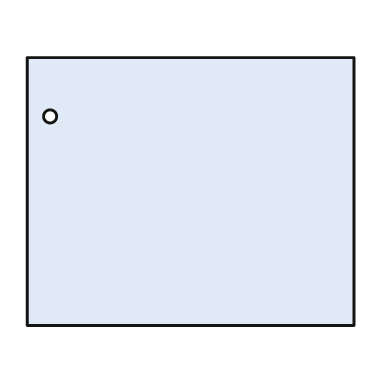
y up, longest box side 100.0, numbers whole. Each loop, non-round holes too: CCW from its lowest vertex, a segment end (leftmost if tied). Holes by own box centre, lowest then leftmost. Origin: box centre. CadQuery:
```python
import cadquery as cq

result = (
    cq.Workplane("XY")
    .moveTo(-50.0, -41.0)
    .lineTo(50.0, -41.0)
    .lineTo(50.0, 41.0)
    .lineTo(-50.0, 41.0)
    .close()
    .moveTo(-43.0, 23.0)
    .circle(2.0)
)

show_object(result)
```